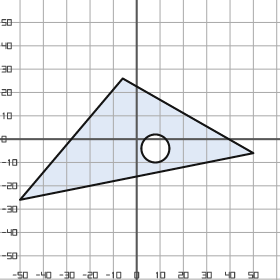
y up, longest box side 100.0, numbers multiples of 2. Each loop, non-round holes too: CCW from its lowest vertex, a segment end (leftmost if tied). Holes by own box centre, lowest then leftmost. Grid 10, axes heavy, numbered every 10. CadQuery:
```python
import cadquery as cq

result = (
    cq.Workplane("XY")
    .moveTo(-50.0, -26.0)
    .lineTo(50.0, -6.0)
    .lineTo(-6.0, 26.0)
    .close()
    .moveTo(8.0, -4.0)
    .circle(6.0)
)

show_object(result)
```